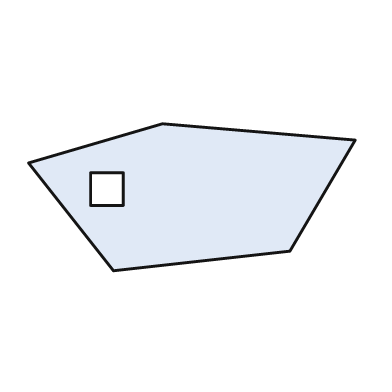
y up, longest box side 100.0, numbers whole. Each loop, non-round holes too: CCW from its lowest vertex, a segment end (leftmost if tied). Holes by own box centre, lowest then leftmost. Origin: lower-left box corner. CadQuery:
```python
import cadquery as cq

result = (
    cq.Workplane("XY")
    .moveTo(26.0, 0.0)
    .lineTo(80.0, 6.0)
    .lineTo(100.0, 40.0)
    .lineTo(41.0, 45.0)
    .lineTo(0.0, 33.0)
    .close()
    .moveTo(19.0, 20.0)
    .lineTo(29.0, 20.0)
    .lineTo(29.0, 30.0)
    .lineTo(19.0, 30.0)
    .close()
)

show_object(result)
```